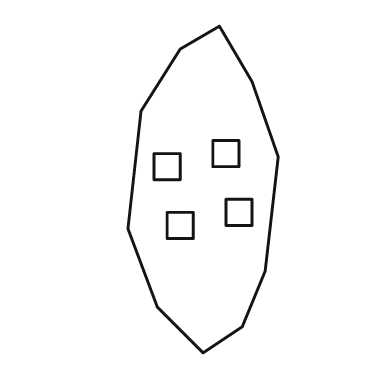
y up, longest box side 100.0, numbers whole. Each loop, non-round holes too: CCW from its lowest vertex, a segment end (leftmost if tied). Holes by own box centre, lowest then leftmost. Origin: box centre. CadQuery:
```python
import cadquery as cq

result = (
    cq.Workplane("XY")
    .moveTo(0.0, -50.0)
    .lineTo(12.0, -42.0)
    .lineTo(19.0, -25.0)
    .lineTo(23.0, 10.0)
    .lineTo(15.0, 33.0)
    .lineTo(5.0, 50.0)
    .lineTo(-7.0, 43.0)
    .lineTo(-19.0, 24.0)
    .lineTo(-23.0, -12.0)
    .lineTo(-14.0, -36.0)
    .close()
    .moveTo(-11.0, -15.0)
    .lineTo(-3.0, -15.0)
    .lineTo(-3.0, -7.0)
    .lineTo(-11.0, -7.0)
    .close()
    .moveTo(7.0, -11.0)
    .lineTo(15.0, -11.0)
    .lineTo(15.0, -3.0)
    .lineTo(7.0, -3.0)
    .close()
    .moveTo(-15.0, 3.0)
    .lineTo(-7.0, 3.0)
    .lineTo(-7.0, 11.0)
    .lineTo(-15.0, 11.0)
    .close()
    .moveTo(3.0, 7.0)
    .lineTo(11.0, 7.0)
    .lineTo(11.0, 15.0)
    .lineTo(3.0, 15.0)
    .close()
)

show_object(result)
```